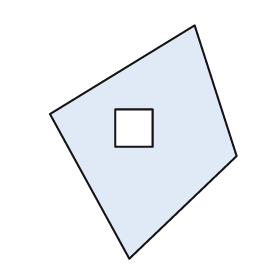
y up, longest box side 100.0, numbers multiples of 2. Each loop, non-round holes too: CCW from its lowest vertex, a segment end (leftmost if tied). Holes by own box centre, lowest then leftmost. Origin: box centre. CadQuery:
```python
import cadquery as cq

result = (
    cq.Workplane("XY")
    .moveTo(-6.0, -50.0)
    .lineTo(40.0, -6.0)
    .lineTo(22.0, 50.0)
    .lineTo(-40.0, 12.0)
    .close()
    .moveTo(-12.0, -2.0)
    .lineTo(4.0, -2.0)
    .lineTo(4.0, 14.0)
    .lineTo(-12.0, 14.0)
    .close()
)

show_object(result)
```